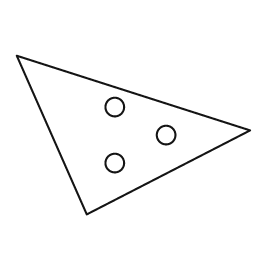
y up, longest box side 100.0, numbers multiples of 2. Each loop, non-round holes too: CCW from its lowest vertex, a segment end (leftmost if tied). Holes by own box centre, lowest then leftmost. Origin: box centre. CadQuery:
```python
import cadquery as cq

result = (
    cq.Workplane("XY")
    .moveTo(-20.0, -34.0)
    .lineTo(50.0, 2.0)
    .lineTo(-50.0, 34.0)
    .close()
    .moveTo(-8.0, -12.0)
    .circle(4.0)
    .moveTo(14.0, 0.0)
    .circle(4.0)
    .moveTo(-8.0, 12.0)
    .circle(4.0)
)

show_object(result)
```